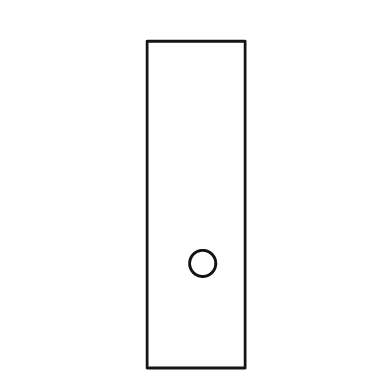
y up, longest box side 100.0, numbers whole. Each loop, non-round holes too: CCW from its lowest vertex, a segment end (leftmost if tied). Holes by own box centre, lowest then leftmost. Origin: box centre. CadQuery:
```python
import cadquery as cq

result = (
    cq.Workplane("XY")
    .moveTo(-15.0, -50.0)
    .lineTo(15.0, -50.0)
    .lineTo(15.0, 50.0)
    .lineTo(-15.0, 50.0)
    .close()
    .moveTo(2.0, -18.0)
    .circle(4.0)
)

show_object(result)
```